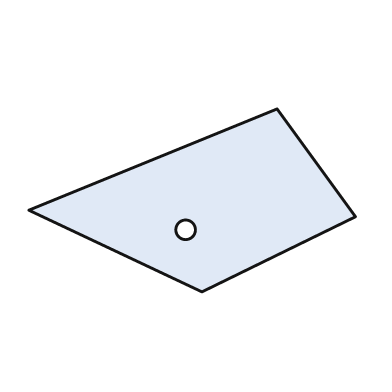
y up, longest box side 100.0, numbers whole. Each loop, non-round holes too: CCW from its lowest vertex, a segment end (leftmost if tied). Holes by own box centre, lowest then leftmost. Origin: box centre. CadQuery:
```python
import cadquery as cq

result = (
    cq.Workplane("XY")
    .moveTo(3.0, -28.0)
    .lineTo(50.0, -5.0)
    .lineTo(26.0, 28.0)
    .lineTo(-50.0, -3.0)
    .close()
    .moveTo(-2.0, -9.0)
    .circle(3.0)
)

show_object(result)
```